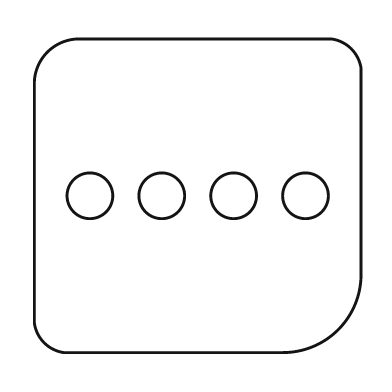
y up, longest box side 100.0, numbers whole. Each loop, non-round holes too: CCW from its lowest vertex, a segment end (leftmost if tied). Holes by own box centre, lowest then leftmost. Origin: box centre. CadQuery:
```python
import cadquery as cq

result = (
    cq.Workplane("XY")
    .moveTo(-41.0, -48.0)
    .lineTo(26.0, -48.0)
    .threePointArc((43.0, -41.0), (50.0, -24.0))
    .lineTo(50.0, 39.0)
    .threePointArc((47.0, 45.0), (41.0, 48.0))
    .lineTo(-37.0, 48.0)
    .threePointArc((-46.0, 44.0), (-50.0, 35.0))
    .lineTo(-50.0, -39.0)
    .threePointArc((-47.0, -45.0), (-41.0, -48.0))
    .close()
    .moveTo(-33.0, 0.0)
    .circle(7.0)
    .moveTo(-11.0, 0.0)
    .circle(7.0)
    .moveTo(11.0, 0.0)
    .circle(7.0)
    .moveTo(33.0, 0.0)
    .circle(7.0)
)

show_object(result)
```